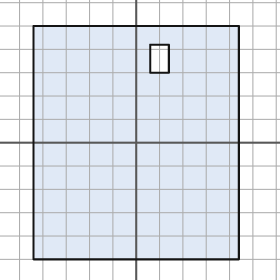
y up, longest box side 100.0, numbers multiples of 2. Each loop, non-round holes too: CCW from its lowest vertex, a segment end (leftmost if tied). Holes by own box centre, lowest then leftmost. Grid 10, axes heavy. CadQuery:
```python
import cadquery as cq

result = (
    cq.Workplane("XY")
    .moveTo(-44.0, -50.0)
    .lineTo(44.0, -50.0)
    .lineTo(44.0, 50.0)
    .lineTo(-44.0, 50.0)
    .close()
    .moveTo(6.0, 30.0)
    .lineTo(14.0, 30.0)
    .lineTo(14.0, 42.0)
    .lineTo(6.0, 42.0)
    .close()
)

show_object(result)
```